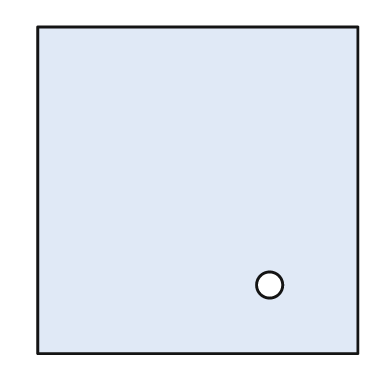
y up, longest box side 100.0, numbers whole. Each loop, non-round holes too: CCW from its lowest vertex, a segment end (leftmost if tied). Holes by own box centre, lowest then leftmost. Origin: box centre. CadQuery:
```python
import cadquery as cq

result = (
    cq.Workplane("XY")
    .moveTo(-49.0, -50.0)
    .lineTo(49.0, -50.0)
    .lineTo(49.0, 50.0)
    .lineTo(-49.0, 50.0)
    .close()
    .moveTo(22.0, -29.0)
    .circle(4.0)
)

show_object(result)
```